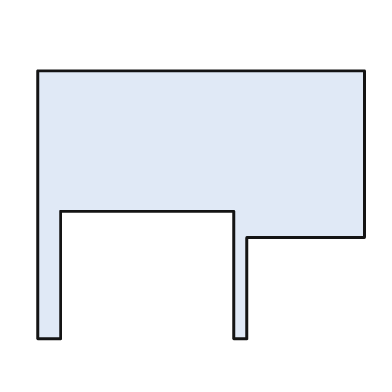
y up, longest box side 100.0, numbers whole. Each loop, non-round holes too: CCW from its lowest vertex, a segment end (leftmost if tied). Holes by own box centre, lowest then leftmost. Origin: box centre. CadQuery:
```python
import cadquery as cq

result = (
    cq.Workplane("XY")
    .moveTo(-50.0, -41.0)
    .lineTo(-43.0, -41.0)
    .lineTo(-43.0, -2.0)
    .lineTo(10.0, -2.0)
    .lineTo(10.0, -41.0)
    .lineTo(14.0, -41.0)
    .lineTo(14.0, -10.0)
    .lineTo(50.0, -10.0)
    .lineTo(50.0, 41.0)
    .lineTo(-50.0, 41.0)
    .close()
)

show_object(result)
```